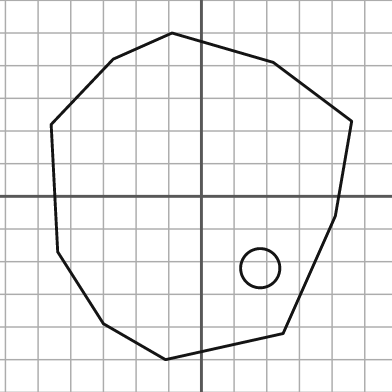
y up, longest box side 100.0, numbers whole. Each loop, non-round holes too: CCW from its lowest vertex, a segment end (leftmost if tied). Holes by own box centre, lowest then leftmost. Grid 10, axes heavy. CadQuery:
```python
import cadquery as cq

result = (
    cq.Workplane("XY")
    .moveTo(-11.0, -50.0)
    .lineTo(25.0, -42.0)
    .lineTo(41.0, -6.0)
    .lineTo(46.0, 23.0)
    .lineTo(22.0, 41.0)
    .lineTo(-9.0, 50.0)
    .lineTo(-27.0, 42.0)
    .lineTo(-46.0, 22.0)
    .lineTo(-44.0, -17.0)
    .lineTo(-30.0, -39.0)
    .close()
    .moveTo(18.0, -22.0)
    .circle(6.0)
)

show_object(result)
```